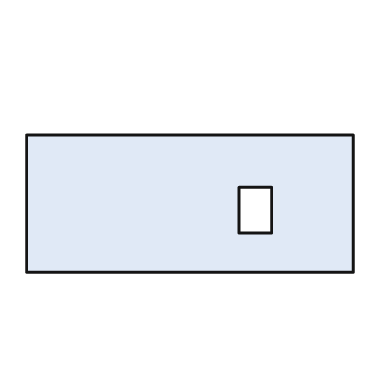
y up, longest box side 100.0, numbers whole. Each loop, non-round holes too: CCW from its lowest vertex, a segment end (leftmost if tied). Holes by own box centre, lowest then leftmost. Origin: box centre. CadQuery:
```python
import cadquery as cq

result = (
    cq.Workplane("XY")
    .moveTo(-50.0, -21.0)
    .lineTo(50.0, -21.0)
    .lineTo(50.0, 21.0)
    .lineTo(-50.0, 21.0)
    .close()
    .moveTo(15.0, -9.0)
    .lineTo(25.0, -9.0)
    .lineTo(25.0, 5.0)
    .lineTo(15.0, 5.0)
    .close()
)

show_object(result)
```